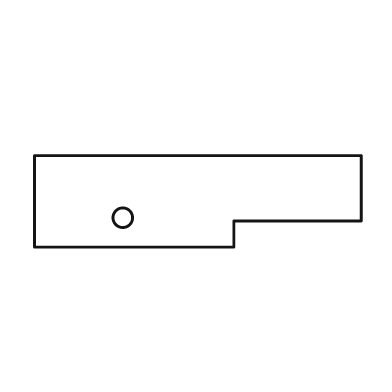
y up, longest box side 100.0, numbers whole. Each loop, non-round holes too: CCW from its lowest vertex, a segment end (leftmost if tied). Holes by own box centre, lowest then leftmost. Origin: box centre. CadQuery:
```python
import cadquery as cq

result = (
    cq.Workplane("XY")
    .moveTo(-50.0, -14.0)
    .lineTo(11.0, -14.0)
    .lineTo(11.0, -6.0)
    .lineTo(50.0, -6.0)
    .lineTo(50.0, 14.0)
    .lineTo(-50.0, 14.0)
    .close()
    .moveTo(-23.0, -5.0)
    .circle(3.0)
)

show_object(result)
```